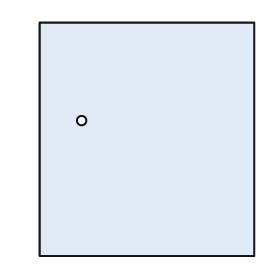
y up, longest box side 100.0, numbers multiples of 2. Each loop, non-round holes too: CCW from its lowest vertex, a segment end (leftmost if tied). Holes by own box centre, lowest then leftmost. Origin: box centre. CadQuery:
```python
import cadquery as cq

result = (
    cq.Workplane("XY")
    .moveTo(-46.0, -50.0)
    .lineTo(46.0, -50.0)
    .lineTo(46.0, 50.0)
    .lineTo(-46.0, 50.0)
    .close()
    .moveTo(-28.0, 8.0)
    .circle(2.0)
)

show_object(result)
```